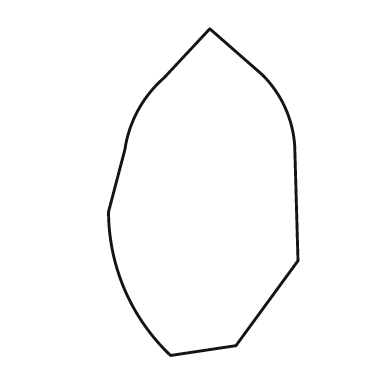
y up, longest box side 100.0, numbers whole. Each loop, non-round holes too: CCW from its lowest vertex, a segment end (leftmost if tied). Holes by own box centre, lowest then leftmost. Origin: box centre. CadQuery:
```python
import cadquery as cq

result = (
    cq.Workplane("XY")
    .moveTo(-10.0, -50.0)
    .lineTo(10.0, -47.0)
    .lineTo(29.0, -21.0)
    .lineTo(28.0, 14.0)
    .threePointArc((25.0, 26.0), (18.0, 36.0))
    .lineTo(2.0, 50.0)
    .lineTo(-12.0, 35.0)
    .threePointArc((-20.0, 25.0), (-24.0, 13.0))
    .lineTo(-29.0, -6.0)
    .threePointArc((-24.0, -30.0), (-10.0, -50.0))
    .close()
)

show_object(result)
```